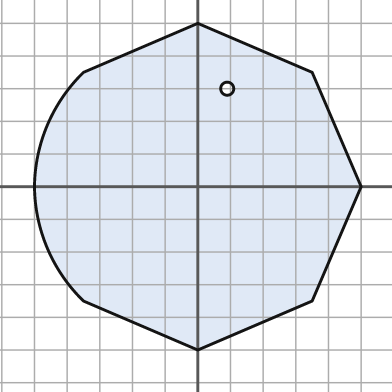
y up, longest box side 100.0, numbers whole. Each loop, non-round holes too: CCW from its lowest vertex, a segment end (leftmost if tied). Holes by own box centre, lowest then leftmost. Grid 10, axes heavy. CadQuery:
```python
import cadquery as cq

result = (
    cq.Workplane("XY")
    .moveTo(0.0, -50.0)
    .lineTo(35.0, -35.0)
    .lineTo(50.0, 0.0)
    .lineTo(35.0, 35.0)
    .lineTo(0.0, 50.0)
    .lineTo(-35.0, 35.0)
    .threePointArc((-46.0, 19.0), (-50.0, 0.0))
    .threePointArc((-46.0, -19.0), (-35.0, -35.0))
    .close()
    .moveTo(9.0, 30.0)
    .circle(2.0)
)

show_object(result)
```